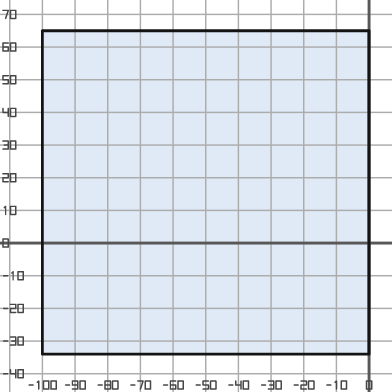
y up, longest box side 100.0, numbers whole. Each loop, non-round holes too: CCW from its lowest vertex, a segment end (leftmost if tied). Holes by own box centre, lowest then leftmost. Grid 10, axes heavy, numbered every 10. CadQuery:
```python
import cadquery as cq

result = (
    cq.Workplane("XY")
    .moveTo(-100.0, -34.0)
    .lineTo(0.0, -34.0)
    .lineTo(0.0, 65.0)
    .lineTo(-100.0, 65.0)
    .close()
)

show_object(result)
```